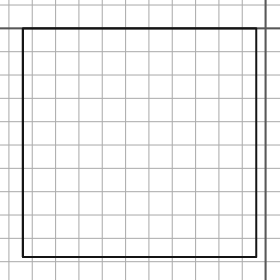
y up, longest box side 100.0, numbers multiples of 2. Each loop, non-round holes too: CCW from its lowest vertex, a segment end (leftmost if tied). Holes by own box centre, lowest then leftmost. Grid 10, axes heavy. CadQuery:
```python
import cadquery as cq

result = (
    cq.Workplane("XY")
    .moveTo(-104.0, -98.0)
    .lineTo(-4.0, -98.0)
    .lineTo(-4.0, 0.0)
    .lineTo(-104.0, 0.0)
    .close()
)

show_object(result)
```